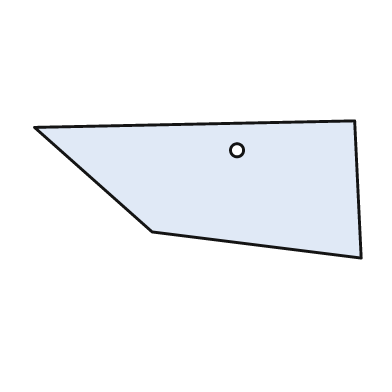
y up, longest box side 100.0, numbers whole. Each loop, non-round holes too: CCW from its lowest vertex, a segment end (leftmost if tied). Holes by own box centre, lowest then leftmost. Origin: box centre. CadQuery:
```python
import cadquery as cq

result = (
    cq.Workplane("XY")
    .moveTo(50.0, -21.0)
    .lineTo(48.0, 21.0)
    .lineTo(-50.0, 19.0)
    .lineTo(-14.0, -13.0)
    .close()
    .moveTo(12.0, 12.0)
    .circle(2.0)
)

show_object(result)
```